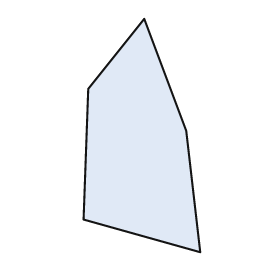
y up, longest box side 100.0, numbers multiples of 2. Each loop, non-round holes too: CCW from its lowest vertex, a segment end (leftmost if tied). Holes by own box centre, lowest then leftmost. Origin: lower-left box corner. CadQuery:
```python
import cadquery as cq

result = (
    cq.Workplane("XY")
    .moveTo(50.0, 0.0)
    .lineTo(44.0, 52.0)
    .lineTo(26.0, 100.0)
    .lineTo(2.0, 70.0)
    .lineTo(0.0, 14.0)
    .close()
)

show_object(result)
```